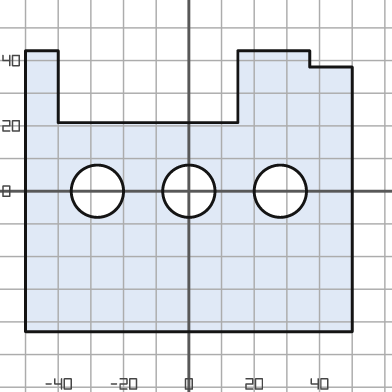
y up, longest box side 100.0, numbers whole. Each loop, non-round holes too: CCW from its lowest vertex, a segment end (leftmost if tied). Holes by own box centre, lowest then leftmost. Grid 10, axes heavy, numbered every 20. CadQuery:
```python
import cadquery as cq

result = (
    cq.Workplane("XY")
    .moveTo(-50.0, -43.0)
    .lineTo(50.0, -43.0)
    .lineTo(50.0, 38.0)
    .lineTo(37.0, 38.0)
    .lineTo(37.0, 43.0)
    .lineTo(15.0, 43.0)
    .lineTo(15.0, 21.0)
    .lineTo(-40.0, 21.0)
    .lineTo(-40.0, 43.0)
    .lineTo(-50.0, 43.0)
    .close()
    .moveTo(-28.0, 0.0)
    .circle(8.0)
    .moveTo(0.0, 0.0)
    .circle(8.0)
    .moveTo(28.0, 0.0)
    .circle(8.0)
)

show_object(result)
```